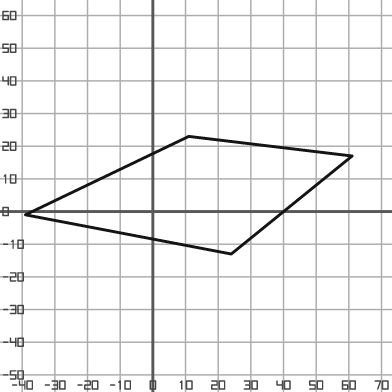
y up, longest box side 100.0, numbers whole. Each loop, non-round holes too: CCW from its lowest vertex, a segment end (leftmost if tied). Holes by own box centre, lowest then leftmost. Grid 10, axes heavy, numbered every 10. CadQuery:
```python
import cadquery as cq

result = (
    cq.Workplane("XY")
    .moveTo(24.0, -13.0)
    .lineTo(61.0, 17.0)
    .lineTo(11.0, 23.0)
    .lineTo(-39.0, -1.0)
    .close()
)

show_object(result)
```